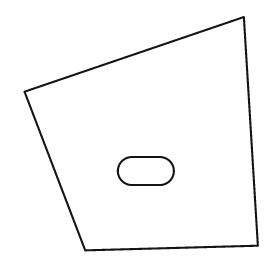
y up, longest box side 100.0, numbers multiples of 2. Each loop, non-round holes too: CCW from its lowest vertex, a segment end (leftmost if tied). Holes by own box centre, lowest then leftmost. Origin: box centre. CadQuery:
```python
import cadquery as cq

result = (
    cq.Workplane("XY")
    .moveTo(-24.0, -50.0)
    .lineTo(50.0, -48.0)
    .lineTo(44.0, 50.0)
    .lineTo(-50.0, 18.0)
    .close()
    .moveTo(-4.0, -22.0)
    .lineTo(8.0, -22.0)
    .threePointArc((14.0, -16.0), (8.0, -10.0))
    .lineTo(-4.0, -10.0)
    .threePointArc((-10.0, -16.0), (-4.0, -22.0))
    .close()
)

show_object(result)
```